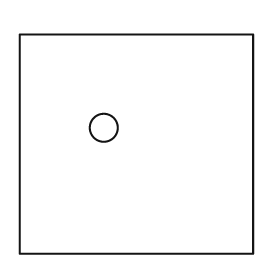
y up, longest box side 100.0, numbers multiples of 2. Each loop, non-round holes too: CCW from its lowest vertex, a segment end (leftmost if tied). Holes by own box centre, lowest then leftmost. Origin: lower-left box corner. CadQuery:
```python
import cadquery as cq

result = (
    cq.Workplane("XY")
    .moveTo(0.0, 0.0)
    .lineTo(100.0, 0.0)
    .lineTo(100.0, 94.0)
    .lineTo(0.0, 94.0)
    .close()
    .moveTo(36.0, 54.0)
    .circle(6.0)
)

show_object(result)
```